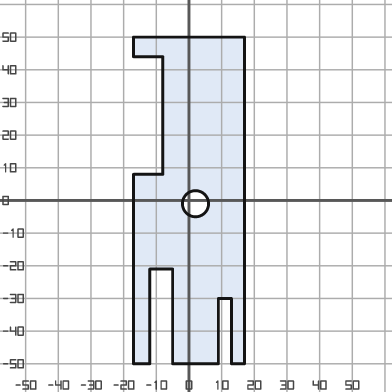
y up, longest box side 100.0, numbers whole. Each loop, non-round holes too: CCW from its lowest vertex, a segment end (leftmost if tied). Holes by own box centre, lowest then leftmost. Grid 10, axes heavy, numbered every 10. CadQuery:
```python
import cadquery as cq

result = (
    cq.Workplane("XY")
    .moveTo(-17.0, -50.0)
    .lineTo(-12.0, -50.0)
    .lineTo(-12.0, -21.0)
    .lineTo(-5.0, -21.0)
    .lineTo(-5.0, -50.0)
    .lineTo(9.0, -50.0)
    .lineTo(9.0, -30.0)
    .lineTo(13.0, -30.0)
    .lineTo(13.0, -50.0)
    .lineTo(17.0, -50.0)
    .lineTo(17.0, 50.0)
    .lineTo(-17.0, 50.0)
    .lineTo(-17.0, 44.0)
    .lineTo(-8.0, 44.0)
    .lineTo(-8.0, 8.0)
    .lineTo(-17.0, 8.0)
    .close()
    .moveTo(2.0, -1.0)
    .circle(4.0)
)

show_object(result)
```